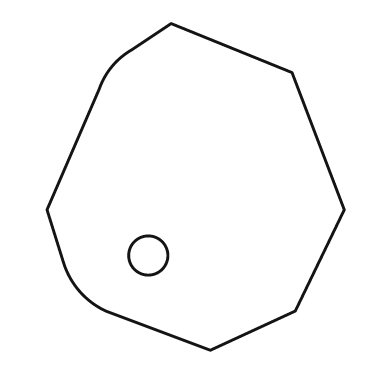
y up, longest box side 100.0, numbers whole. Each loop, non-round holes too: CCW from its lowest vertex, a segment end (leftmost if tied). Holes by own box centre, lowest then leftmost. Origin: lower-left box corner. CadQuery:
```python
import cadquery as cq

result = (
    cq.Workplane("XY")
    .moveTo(50.0, 0.0)
    .lineTo(76.0, 12.0)
    .lineTo(91.0, 43.0)
    .lineTo(75.0, 85.0)
    .lineTo(38.0, 100.0)
    .lineTo(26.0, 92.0)
    .threePointArc((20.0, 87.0), (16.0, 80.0))
    .lineTo(0.0, 43.0)
    .lineTo(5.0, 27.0)
    .threePointArc((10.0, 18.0), (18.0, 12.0))
    .close()
    .moveTo(31.0, 29.0)
    .circle(6.0)
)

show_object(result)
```